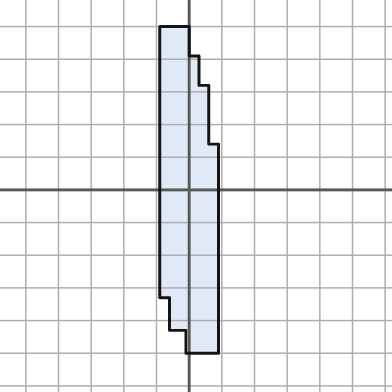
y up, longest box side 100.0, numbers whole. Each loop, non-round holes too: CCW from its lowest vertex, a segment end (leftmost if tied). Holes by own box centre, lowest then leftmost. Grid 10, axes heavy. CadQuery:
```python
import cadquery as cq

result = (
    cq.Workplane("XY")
    .moveTo(-1.0, -50.0)
    .lineTo(9.0, -50.0)
    .lineTo(9.0, 14.0)
    .lineTo(6.0, 14.0)
    .lineTo(6.0, 32.0)
    .lineTo(3.0, 32.0)
    .lineTo(3.0, 41.0)
    .lineTo(0.0, 41.0)
    .lineTo(0.0, 50.0)
    .lineTo(-9.0, 50.0)
    .lineTo(-9.0, -33.0)
    .lineTo(-6.0, -33.0)
    .lineTo(-6.0, -43.0)
    .lineTo(-1.0, -43.0)
    .close()
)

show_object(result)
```